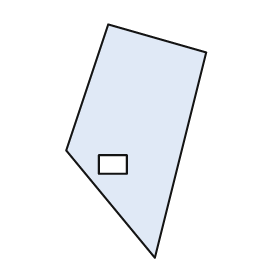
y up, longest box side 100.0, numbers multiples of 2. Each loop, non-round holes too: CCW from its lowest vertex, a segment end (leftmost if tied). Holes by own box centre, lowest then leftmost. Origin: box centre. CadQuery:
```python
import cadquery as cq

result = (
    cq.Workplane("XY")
    .moveTo(8.0, -50.0)
    .lineTo(30.0, 38.0)
    .lineTo(-12.0, 50.0)
    .lineTo(-30.0, -4.0)
    .close()
    .moveTo(-16.0, -14.0)
    .lineTo(-4.0, -14.0)
    .lineTo(-4.0, -6.0)
    .lineTo(-16.0, -6.0)
    .close()
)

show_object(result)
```